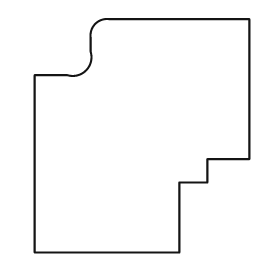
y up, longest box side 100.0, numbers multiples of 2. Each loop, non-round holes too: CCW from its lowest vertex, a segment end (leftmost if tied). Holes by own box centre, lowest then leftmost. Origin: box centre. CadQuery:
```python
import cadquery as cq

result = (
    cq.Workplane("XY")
    .moveTo(-46.0, -50.0)
    .lineTo(16.0, -50.0)
    .lineTo(16.0, -20.0)
    .lineTo(28.0, -20.0)
    .lineTo(28.0, -10.0)
    .lineTo(46.0, -10.0)
    .lineTo(46.0, 50.0)
    .lineTo(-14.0, 50.0)
    .threePointArc((-20.0, 48.0), (-22.0, 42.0))
    .lineTo(-22.0, 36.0)
    .threePointArc((-24.0, 28.0), (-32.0, 26.0))
    .lineTo(-46.0, 26.0)
    .close()
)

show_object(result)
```